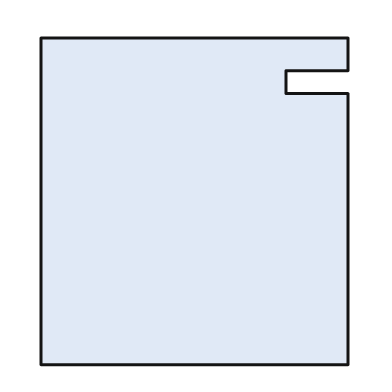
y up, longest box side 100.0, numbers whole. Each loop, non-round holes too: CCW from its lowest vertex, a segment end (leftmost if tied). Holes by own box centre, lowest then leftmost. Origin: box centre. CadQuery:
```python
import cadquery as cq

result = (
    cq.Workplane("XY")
    .moveTo(-47.0, -50.0)
    .lineTo(47.0, -50.0)
    .lineTo(47.0, 33.0)
    .lineTo(28.0, 33.0)
    .lineTo(28.0, 40.0)
    .lineTo(47.0, 40.0)
    .lineTo(47.0, 50.0)
    .lineTo(-47.0, 50.0)
    .close()
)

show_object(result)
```